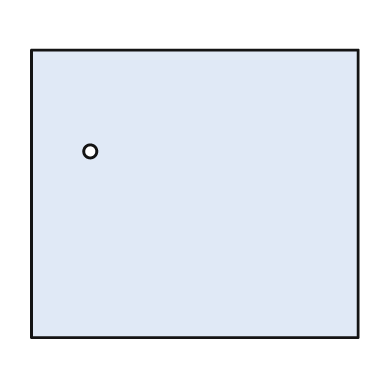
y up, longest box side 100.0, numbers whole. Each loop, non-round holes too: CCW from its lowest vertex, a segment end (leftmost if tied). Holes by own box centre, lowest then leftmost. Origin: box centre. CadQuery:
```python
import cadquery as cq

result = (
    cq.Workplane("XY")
    .moveTo(-50.0, -44.0)
    .lineTo(50.0, -44.0)
    .lineTo(50.0, 44.0)
    .lineTo(-50.0, 44.0)
    .close()
    .moveTo(-32.0, 13.0)
    .circle(2.0)
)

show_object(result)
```